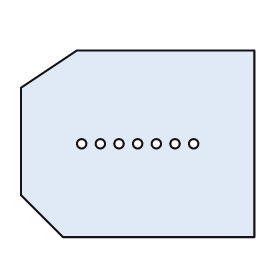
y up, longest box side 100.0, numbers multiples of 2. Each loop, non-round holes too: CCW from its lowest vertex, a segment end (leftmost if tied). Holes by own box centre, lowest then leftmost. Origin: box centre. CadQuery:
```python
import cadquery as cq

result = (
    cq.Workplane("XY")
    .moveTo(-32.0, -40.0)
    .lineTo(50.0, -40.0)
    .lineTo(50.0, 40.0)
    .lineTo(-26.0, 40.0)
    .lineTo(-50.0, 24.0)
    .lineTo(-50.0, -22.0)
    .close()
    .moveTo(-24.0, 0.0)
    .circle(2.0)
    .moveTo(-16.0, 0.0)
    .circle(2.0)
    .moveTo(-8.0, 0.0)
    .circle(2.0)
    .moveTo(0.0, 0.0)
    .circle(2.0)
    .moveTo(8.0, 0.0)
    .circle(2.0)
    .moveTo(16.0, 0.0)
    .circle(2.0)
    .moveTo(24.0, 0.0)
    .circle(2.0)
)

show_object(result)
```